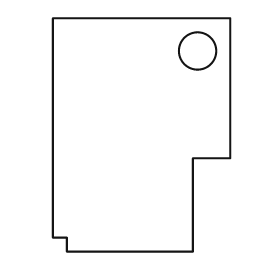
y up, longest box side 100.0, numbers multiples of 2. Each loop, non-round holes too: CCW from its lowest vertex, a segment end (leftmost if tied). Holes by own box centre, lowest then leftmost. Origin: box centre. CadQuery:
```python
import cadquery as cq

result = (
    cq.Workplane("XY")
    .moveTo(-32.0, -50.0)
    .lineTo(22.0, -50.0)
    .lineTo(22.0, -10.0)
    .lineTo(38.0, -10.0)
    .lineTo(38.0, 50.0)
    .lineTo(-38.0, 50.0)
    .lineTo(-38.0, -44.0)
    .lineTo(-32.0, -44.0)
    .close()
    .moveTo(24.0, 36.0)
    .circle(8.0)
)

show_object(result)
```